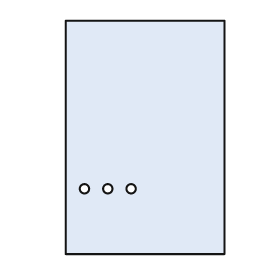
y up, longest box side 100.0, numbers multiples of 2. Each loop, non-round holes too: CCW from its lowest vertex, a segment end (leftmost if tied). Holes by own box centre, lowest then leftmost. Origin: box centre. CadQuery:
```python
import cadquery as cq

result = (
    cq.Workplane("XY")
    .moveTo(-34.0, -50.0)
    .lineTo(34.0, -50.0)
    .lineTo(34.0, 50.0)
    .lineTo(-34.0, 50.0)
    .close()
    .moveTo(-26.0, -22.0)
    .circle(2.0)
    .moveTo(-16.0, -22.0)
    .circle(2.0)
    .moveTo(-6.0, -22.0)
    .circle(2.0)
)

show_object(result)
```